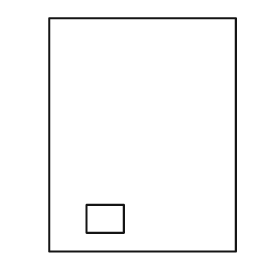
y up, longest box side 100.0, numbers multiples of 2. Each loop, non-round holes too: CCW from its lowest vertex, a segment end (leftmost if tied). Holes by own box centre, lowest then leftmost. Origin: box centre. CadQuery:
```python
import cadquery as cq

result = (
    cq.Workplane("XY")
    .moveTo(-40.0, -50.0)
    .lineTo(40.0, -50.0)
    .lineTo(40.0, 50.0)
    .lineTo(-40.0, 50.0)
    .close()
    .moveTo(-24.0, -42.0)
    .lineTo(-8.0, -42.0)
    .lineTo(-8.0, -30.0)
    .lineTo(-24.0, -30.0)
    .close()
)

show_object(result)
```